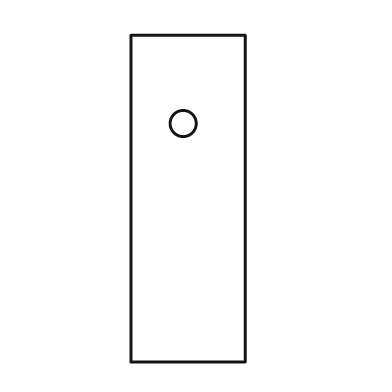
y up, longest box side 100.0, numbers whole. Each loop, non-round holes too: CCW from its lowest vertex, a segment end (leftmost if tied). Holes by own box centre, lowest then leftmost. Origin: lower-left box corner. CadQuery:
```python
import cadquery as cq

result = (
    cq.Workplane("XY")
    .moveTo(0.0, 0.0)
    .lineTo(35.0, 0.0)
    .lineTo(35.0, 100.0)
    .lineTo(0.0, 100.0)
    .close()
    .moveTo(16.0, 73.0)
    .circle(4.0)
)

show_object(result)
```